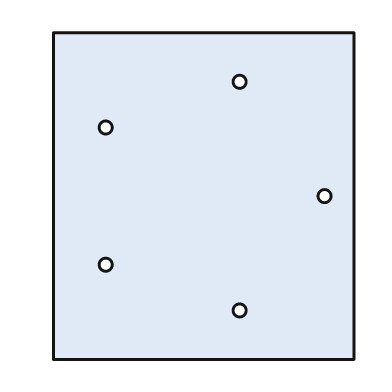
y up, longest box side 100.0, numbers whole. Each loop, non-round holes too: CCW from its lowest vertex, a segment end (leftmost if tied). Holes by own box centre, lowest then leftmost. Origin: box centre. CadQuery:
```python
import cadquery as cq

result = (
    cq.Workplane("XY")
    .moveTo(-46.0, -50.0)
    .lineTo(46.0, -50.0)
    .lineTo(46.0, 50.0)
    .lineTo(-46.0, 50.0)
    .close()
    .moveTo(11.0, -35.0)
    .circle(2.0)
    .moveTo(-30.0, -21.0)
    .circle(2.0)
    .moveTo(37.0, 0.0)
    .circle(2.0)
    .moveTo(-30.0, 21.0)
    .circle(2.0)
    .moveTo(11.0, 35.0)
    .circle(2.0)
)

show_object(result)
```